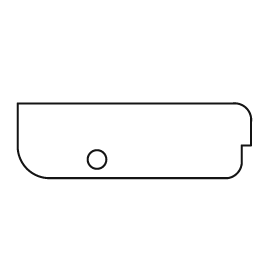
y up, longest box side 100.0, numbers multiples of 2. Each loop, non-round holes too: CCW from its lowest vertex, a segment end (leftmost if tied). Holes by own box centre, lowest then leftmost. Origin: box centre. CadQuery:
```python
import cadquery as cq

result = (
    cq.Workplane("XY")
    .moveTo(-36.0, -16.0)
    .lineTo(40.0, -16.0)
    .threePointArc((44.0, -14.0), (46.0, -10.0))
    .lineTo(46.0, -2.0)
    .lineTo(50.0, -2.0)
    .lineTo(50.0, 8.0)
    .threePointArc((48.0, 14.0), (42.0, 16.0))
    .lineTo(-50.0, 16.0)
    .lineTo(-50.0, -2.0)
    .threePointArc((-46.0, -12.0), (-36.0, -16.0))
    .close()
    .moveTo(-16.0, -8.0)
    .circle(4.0)
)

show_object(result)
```